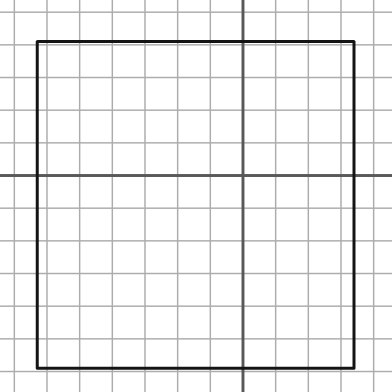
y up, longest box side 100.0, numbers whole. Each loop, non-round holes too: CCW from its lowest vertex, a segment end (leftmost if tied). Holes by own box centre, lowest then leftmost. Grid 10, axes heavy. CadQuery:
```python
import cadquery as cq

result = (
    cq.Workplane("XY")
    .moveTo(-63.0, -59.0)
    .lineTo(34.0, -59.0)
    .lineTo(34.0, 41.0)
    .lineTo(-63.0, 41.0)
    .close()
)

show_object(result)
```